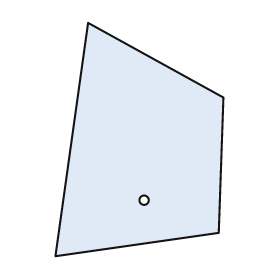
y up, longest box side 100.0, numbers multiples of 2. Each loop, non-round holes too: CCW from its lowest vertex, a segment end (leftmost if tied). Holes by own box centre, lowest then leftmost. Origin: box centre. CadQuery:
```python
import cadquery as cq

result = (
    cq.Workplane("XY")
    .moveTo(-36.0, -50.0)
    .lineTo(34.0, -40.0)
    .lineTo(36.0, 18.0)
    .lineTo(-22.0, 50.0)
    .close()
    .moveTo(2.0, -26.0)
    .circle(2.0)
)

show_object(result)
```